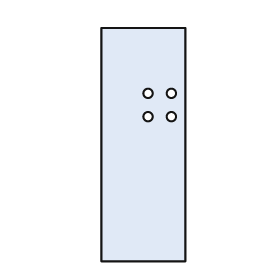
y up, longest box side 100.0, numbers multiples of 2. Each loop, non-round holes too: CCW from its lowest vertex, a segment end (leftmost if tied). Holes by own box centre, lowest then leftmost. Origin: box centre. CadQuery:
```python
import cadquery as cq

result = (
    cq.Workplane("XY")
    .moveTo(-18.0, -50.0)
    .lineTo(18.0, -50.0)
    .lineTo(18.0, 50.0)
    .lineTo(-18.0, 50.0)
    .close()
    .moveTo(2.0, 12.0)
    .circle(2.0)
    .moveTo(12.0, 12.0)
    .circle(2.0)
    .moveTo(2.0, 22.0)
    .circle(2.0)
    .moveTo(12.0, 22.0)
    .circle(2.0)
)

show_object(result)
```